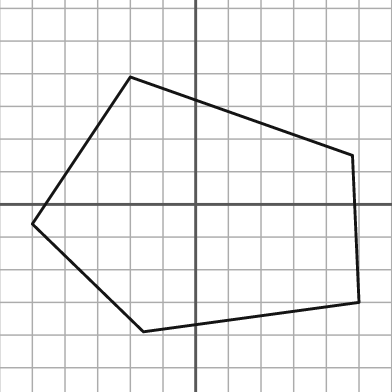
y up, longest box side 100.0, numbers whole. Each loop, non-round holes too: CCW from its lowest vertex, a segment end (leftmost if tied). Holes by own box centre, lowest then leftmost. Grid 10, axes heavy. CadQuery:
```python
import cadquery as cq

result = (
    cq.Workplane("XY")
    .moveTo(-16.0, -39.0)
    .lineTo(50.0, -30.0)
    .lineTo(48.0, 15.0)
    .lineTo(-20.0, 39.0)
    .lineTo(-50.0, -6.0)
    .close()
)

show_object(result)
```